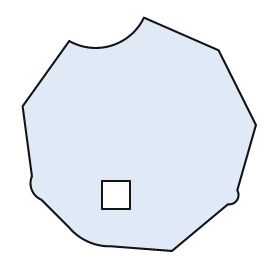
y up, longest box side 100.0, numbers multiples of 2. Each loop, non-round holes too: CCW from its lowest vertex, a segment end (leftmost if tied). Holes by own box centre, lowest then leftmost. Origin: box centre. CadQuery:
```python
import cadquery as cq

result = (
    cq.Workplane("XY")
    .moveTo(14.0, -50.0)
    .lineTo(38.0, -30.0)
    .threePointArc((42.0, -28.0), (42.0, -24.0))
    .lineTo(50.0, 4.0)
    .lineTo(34.0, 36.0)
    .lineTo(2.0, 50.0)
    .threePointArc((-12.0, 38.0), (-30.0, 40.0))
    .lineTo(-50.0, 12.0)
    .lineTo(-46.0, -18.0)
    .threePointArc((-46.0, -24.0), (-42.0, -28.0))
    .lineTo(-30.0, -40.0)
    .threePointArc((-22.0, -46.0), (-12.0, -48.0))
    .close()
    .moveTo(-16.0, -32.0)
    .lineTo(-4.0, -32.0)
    .lineTo(-4.0, -20.0)
    .lineTo(-16.0, -20.0)
    .close()
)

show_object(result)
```